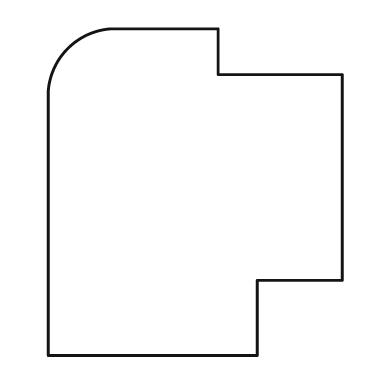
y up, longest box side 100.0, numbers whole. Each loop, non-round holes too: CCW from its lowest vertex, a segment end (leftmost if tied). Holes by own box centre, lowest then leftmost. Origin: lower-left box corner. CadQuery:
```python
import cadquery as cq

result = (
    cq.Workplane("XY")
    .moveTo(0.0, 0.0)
    .lineTo(64.0, 0.0)
    .lineTo(64.0, 23.0)
    .lineTo(90.0, 23.0)
    .lineTo(90.0, 86.0)
    .lineTo(52.0, 86.0)
    .lineTo(52.0, 100.0)
    .lineTo(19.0, 100.0)
    .threePointArc((6.0, 94.0), (0.0, 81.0))
    .close()
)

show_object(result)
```